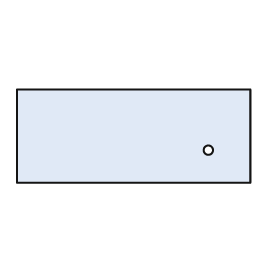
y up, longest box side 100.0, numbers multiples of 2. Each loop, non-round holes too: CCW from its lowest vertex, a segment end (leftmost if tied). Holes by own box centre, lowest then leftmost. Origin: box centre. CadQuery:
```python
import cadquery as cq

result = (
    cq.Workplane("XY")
    .moveTo(-50.0, -20.0)
    .lineTo(50.0, -20.0)
    .lineTo(50.0, 20.0)
    .lineTo(-50.0, 20.0)
    .close()
    .moveTo(32.0, -6.0)
    .circle(2.0)
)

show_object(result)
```